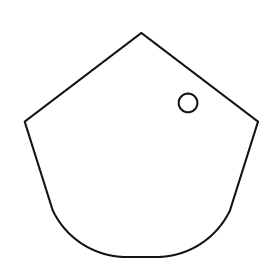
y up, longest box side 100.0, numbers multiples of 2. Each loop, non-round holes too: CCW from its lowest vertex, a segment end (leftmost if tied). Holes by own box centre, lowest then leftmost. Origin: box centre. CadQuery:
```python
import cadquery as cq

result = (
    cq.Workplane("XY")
    .moveTo(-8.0, -48.0)
    .lineTo(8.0, -48.0)
    .threePointArc((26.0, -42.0), (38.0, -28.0))
    .lineTo(50.0, 10.0)
    .lineTo(0.0, 48.0)
    .lineTo(-50.0, 10.0)
    .lineTo(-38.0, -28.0)
    .threePointArc((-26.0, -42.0), (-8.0, -48.0))
    .close()
    .moveTo(20.0, 18.0)
    .circle(4.0)
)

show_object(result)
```